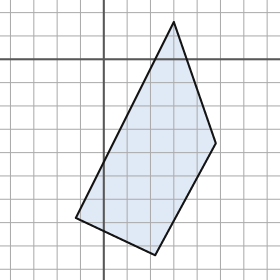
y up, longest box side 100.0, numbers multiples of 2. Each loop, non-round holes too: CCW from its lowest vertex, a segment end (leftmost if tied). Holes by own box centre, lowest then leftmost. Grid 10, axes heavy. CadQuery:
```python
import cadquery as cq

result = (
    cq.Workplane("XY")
    .moveTo(22.0, -84.0)
    .lineTo(48.0, -36.0)
    .lineTo(30.0, 16.0)
    .lineTo(-12.0, -68.0)
    .close()
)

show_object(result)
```